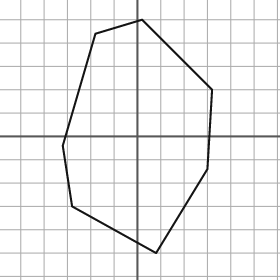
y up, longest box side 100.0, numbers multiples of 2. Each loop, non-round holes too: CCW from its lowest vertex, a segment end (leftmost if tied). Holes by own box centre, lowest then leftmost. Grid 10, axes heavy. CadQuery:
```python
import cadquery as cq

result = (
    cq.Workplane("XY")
    .moveTo(8.0, -50.0)
    .lineTo(30.0, -14.0)
    .lineTo(32.0, 20.0)
    .lineTo(2.0, 50.0)
    .lineTo(-18.0, 44.0)
    .lineTo(-32.0, -4.0)
    .lineTo(-28.0, -30.0)
    .close()
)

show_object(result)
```